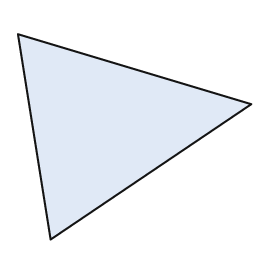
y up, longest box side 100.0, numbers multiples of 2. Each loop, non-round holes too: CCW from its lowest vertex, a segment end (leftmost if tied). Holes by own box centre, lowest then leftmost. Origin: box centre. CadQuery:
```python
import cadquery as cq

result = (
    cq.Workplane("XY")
    .moveTo(-36.0, -44.0)
    .lineTo(50.0, 14.0)
    .lineTo(-50.0, 44.0)
    .close()
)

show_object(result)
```